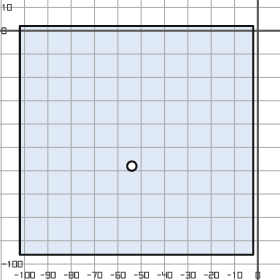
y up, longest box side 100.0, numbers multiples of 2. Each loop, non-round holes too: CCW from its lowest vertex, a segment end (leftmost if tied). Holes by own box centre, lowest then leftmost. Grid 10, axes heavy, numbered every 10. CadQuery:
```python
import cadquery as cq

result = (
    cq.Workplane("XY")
    .moveTo(-102.0, -96.0)
    .lineTo(-2.0, -96.0)
    .lineTo(-2.0, 2.0)
    .lineTo(-102.0, 2.0)
    .close()
    .moveTo(-54.0, -58.0)
    .circle(2.0)
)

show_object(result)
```